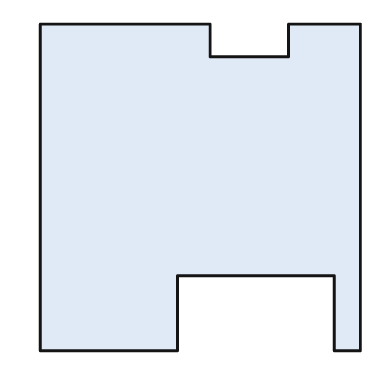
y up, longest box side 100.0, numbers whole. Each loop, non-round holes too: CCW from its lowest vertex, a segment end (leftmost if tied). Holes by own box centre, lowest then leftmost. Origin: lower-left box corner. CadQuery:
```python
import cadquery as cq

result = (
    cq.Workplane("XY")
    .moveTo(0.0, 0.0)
    .lineTo(42.0, 0.0)
    .lineTo(42.0, 23.0)
    .lineTo(90.0, 23.0)
    .lineTo(90.0, 0.0)
    .lineTo(98.0, 0.0)
    .lineTo(98.0, 100.0)
    .lineTo(76.0, 100.0)
    .lineTo(76.0, 90.0)
    .lineTo(52.0, 90.0)
    .lineTo(52.0, 100.0)
    .lineTo(0.0, 100.0)
    .close()
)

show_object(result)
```